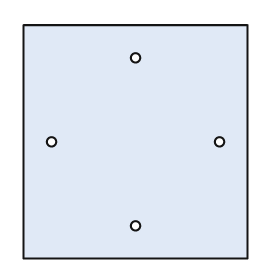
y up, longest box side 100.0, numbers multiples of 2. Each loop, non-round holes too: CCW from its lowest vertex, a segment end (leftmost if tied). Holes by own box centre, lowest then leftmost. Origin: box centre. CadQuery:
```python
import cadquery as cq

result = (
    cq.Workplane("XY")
    .moveTo(-48.0, -50.0)
    .lineTo(48.0, -50.0)
    .lineTo(48.0, 50.0)
    .lineTo(-48.0, 50.0)
    .close()
    .moveTo(0.0, -36.0)
    .circle(2.0)
    .moveTo(-36.0, 0.0)
    .circle(2.0)
    .moveTo(36.0, 0.0)
    .circle(2.0)
    .moveTo(0.0, 36.0)
    .circle(2.0)
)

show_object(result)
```